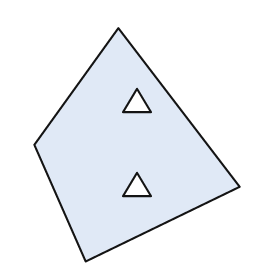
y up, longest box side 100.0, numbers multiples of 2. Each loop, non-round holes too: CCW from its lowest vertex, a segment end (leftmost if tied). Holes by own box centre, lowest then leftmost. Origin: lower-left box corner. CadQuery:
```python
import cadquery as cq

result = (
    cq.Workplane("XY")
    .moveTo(22.0, 0.0)
    .lineTo(88.0, 32.0)
    .lineTo(36.0, 100.0)
    .lineTo(0.0, 50.0)
    .close()
    .moveTo(38.0, 28.0)
    .lineTo(50.0, 28.0)
    .lineTo(44.0, 38.0)
    .close()
    .moveTo(38.0, 64.0)
    .lineTo(50.0, 64.0)
    .lineTo(44.0, 74.0)
    .close()
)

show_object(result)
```